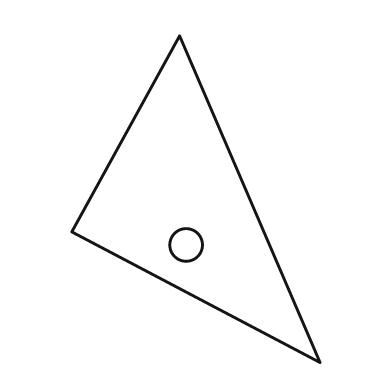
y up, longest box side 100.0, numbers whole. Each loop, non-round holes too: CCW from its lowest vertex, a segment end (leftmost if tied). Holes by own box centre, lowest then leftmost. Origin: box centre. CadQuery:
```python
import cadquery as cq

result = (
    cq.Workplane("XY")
    .moveTo(38.0, -50.0)
    .lineTo(-5.0, 50.0)
    .lineTo(-38.0, -10.0)
    .close()
    .moveTo(-3.0, -14.0)
    .circle(5.0)
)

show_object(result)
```